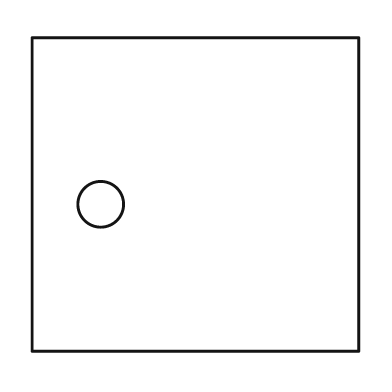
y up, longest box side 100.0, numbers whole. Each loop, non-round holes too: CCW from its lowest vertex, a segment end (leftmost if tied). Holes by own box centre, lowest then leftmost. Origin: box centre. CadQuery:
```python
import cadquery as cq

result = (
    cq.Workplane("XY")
    .moveTo(-50.0, -48.0)
    .lineTo(50.0, -48.0)
    .lineTo(50.0, 48.0)
    .lineTo(-50.0, 48.0)
    .close()
    .moveTo(-29.0, -3.0)
    .circle(7.0)
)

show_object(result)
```